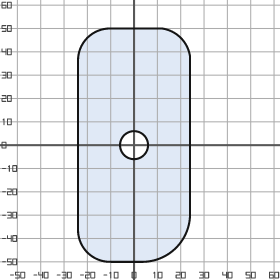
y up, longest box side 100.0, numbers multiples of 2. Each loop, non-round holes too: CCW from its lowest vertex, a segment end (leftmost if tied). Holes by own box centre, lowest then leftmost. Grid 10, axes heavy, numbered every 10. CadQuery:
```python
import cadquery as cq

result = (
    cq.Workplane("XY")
    .moveTo(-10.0, -50.0)
    .lineTo(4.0, -50.0)
    .threePointArc((18.0, -44.0), (24.0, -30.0))
    .lineTo(24.0, 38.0)
    .threePointArc((20.0, 46.0), (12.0, 50.0))
    .lineTo(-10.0, 50.0)
    .threePointArc((-20.0, 46.0), (-24.0, 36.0))
    .lineTo(-24.0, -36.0)
    .threePointArc((-20.0, -46.0), (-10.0, -50.0))
    .close()
    .moveTo(0.0, 0.0)
    .circle(6.0)
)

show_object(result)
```